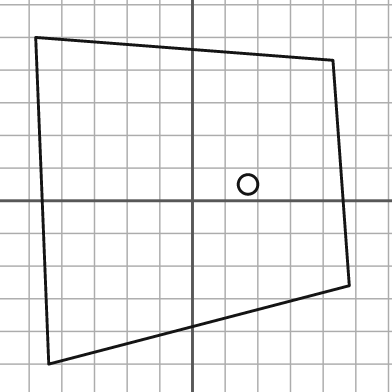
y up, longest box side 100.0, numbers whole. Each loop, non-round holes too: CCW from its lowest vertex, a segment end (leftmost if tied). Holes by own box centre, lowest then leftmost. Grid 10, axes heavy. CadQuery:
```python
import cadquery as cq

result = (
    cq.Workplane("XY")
    .moveTo(-44.0, -50.0)
    .lineTo(48.0, -26.0)
    .lineTo(43.0, 43.0)
    .lineTo(-48.0, 50.0)
    .close()
    .moveTo(17.0, 5.0)
    .circle(3.0)
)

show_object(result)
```